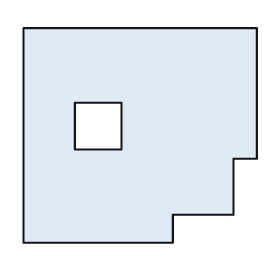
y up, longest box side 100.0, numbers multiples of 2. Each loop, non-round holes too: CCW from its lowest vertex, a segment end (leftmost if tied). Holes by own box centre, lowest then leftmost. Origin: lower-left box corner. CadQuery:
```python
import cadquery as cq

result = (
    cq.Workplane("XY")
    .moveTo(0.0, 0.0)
    .lineTo(64.0, 0.0)
    .lineTo(64.0, 12.0)
    .lineTo(90.0, 12.0)
    .lineTo(90.0, 36.0)
    .lineTo(100.0, 36.0)
    .lineTo(100.0, 92.0)
    .lineTo(0.0, 92.0)
    .close()
    .moveTo(22.0, 40.0)
    .lineTo(42.0, 40.0)
    .lineTo(42.0, 60.0)
    .lineTo(22.0, 60.0)
    .close()
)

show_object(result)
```